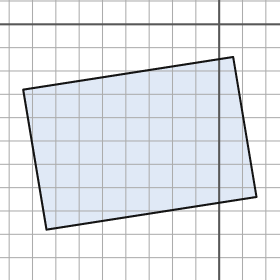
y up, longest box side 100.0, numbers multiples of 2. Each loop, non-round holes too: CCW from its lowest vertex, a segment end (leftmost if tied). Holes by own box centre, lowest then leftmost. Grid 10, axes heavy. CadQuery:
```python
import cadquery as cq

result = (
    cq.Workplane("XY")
    .moveTo(-74.0, -88.0)
    .lineTo(16.0, -74.0)
    .lineTo(6.0, -14.0)
    .lineTo(-84.0, -28.0)
    .close()
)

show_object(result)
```